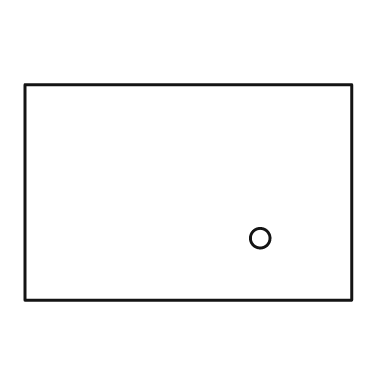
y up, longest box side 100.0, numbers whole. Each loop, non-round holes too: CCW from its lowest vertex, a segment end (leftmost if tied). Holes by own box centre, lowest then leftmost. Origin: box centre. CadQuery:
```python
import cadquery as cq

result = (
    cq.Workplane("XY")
    .moveTo(-50.0, -33.0)
    .lineTo(50.0, -33.0)
    .lineTo(50.0, 33.0)
    .lineTo(-50.0, 33.0)
    .close()
    .moveTo(22.0, -14.0)
    .circle(3.0)
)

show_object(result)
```